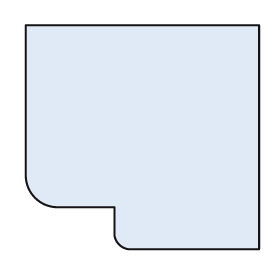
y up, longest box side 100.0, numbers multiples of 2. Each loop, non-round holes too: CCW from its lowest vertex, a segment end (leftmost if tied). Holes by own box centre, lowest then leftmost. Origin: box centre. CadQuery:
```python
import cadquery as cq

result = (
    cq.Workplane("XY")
    .moveTo(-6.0, -48.0)
    .lineTo(50.0, -48.0)
    .lineTo(50.0, 48.0)
    .lineTo(-50.0, 48.0)
    .lineTo(-50.0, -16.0)
    .threePointArc((-46.0, -26.0), (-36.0, -30.0))
    .lineTo(-12.0, -30.0)
    .lineTo(-12.0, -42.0)
    .threePointArc((-10.0, -46.0), (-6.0, -48.0))
    .close()
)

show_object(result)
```